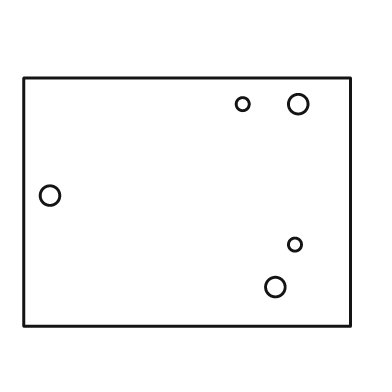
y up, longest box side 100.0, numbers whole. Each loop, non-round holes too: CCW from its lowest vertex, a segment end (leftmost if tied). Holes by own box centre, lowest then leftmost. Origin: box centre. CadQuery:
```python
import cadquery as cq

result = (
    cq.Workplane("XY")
    .moveTo(-50.0, -38.0)
    .lineTo(50.0, -38.0)
    .lineTo(50.0, 38.0)
    .lineTo(-50.0, 38.0)
    .close()
    .moveTo(27.0, -26.0)
    .circle(3.0)
    .moveTo(33.0, -13.0)
    .circle(2.0)
    .moveTo(-42.0, 2.0)
    .circle(3.0)
    .moveTo(17.0, 30.0)
    .circle(2.0)
    .moveTo(34.0, 30.0)
    .circle(3.0)
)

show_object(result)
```